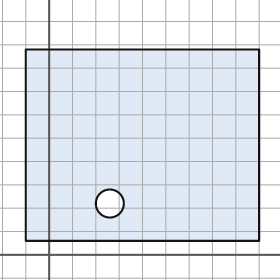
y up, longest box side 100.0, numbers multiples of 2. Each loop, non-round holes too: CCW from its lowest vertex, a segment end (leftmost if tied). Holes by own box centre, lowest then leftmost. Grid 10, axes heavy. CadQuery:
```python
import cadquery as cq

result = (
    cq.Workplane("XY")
    .moveTo(-10.0, 6.0)
    .lineTo(90.0, 6.0)
    .lineTo(90.0, 88.0)
    .lineTo(-10.0, 88.0)
    .close()
    .moveTo(26.0, 22.0)
    .circle(6.0)
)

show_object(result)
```